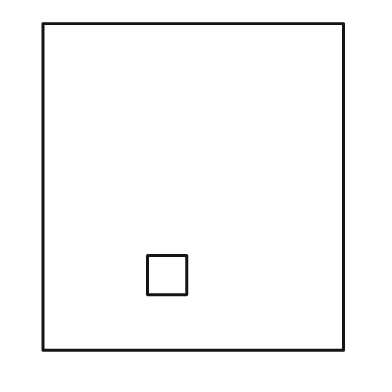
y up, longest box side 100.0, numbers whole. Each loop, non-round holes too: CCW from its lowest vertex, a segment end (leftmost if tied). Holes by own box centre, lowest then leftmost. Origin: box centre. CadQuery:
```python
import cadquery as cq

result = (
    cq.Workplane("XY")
    .moveTo(-46.0, -50.0)
    .lineTo(46.0, -50.0)
    .lineTo(46.0, 50.0)
    .lineTo(-46.0, 50.0)
    .close()
    .moveTo(-14.0, -33.0)
    .lineTo(-2.0, -33.0)
    .lineTo(-2.0, -21.0)
    .lineTo(-14.0, -21.0)
    .close()
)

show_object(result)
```